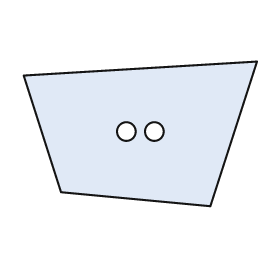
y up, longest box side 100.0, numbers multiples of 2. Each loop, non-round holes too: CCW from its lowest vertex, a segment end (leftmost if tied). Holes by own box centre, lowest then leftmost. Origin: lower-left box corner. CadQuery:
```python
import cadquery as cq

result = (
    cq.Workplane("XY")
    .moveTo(80.0, 0.0)
    .lineTo(100.0, 62.0)
    .lineTo(0.0, 56.0)
    .lineTo(16.0, 6.0)
    .close()
    .moveTo(44.0, 32.0)
    .circle(4.0)
    .moveTo(56.0, 32.0)
    .circle(4.0)
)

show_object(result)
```